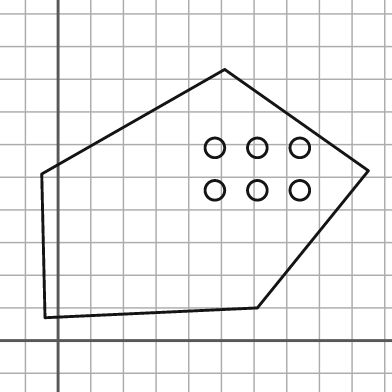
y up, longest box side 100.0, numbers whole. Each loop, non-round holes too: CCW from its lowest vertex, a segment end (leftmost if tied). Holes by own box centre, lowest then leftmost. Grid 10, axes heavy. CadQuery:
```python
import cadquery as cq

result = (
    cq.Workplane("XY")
    .moveTo(-4.0, 7.0)
    .lineTo(61.0, 10.0)
    .lineTo(95.0, 52.0)
    .lineTo(51.0, 83.0)
    .lineTo(-5.0, 51.0)
    .close()
    .moveTo(48.0, 46.0)
    .circle(3.0)
    .moveTo(61.0, 46.0)
    .circle(3.0)
    .moveTo(74.0, 46.0)
    .circle(3.0)
    .moveTo(48.0, 59.0)
    .circle(3.0)
    .moveTo(61.0, 59.0)
    .circle(3.0)
    .moveTo(74.0, 59.0)
    .circle(3.0)
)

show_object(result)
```